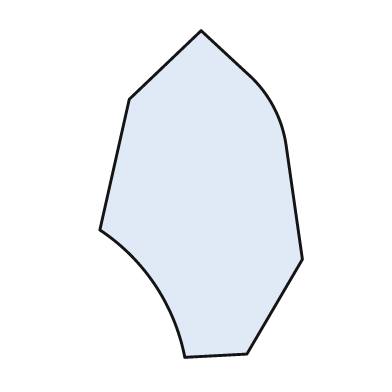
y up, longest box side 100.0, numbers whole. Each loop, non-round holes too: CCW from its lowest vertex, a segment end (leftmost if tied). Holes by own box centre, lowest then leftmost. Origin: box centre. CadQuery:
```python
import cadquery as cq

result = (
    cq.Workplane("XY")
    .moveTo(-5.0, -50.0)
    .lineTo(14.0, -49.0)
    .lineTo(31.0, -20.0)
    .lineTo(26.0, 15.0)
    .threePointArc((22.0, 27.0), (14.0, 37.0))
    .lineTo(0.0, 50.0)
    .lineTo(-22.0, 29.0)
    .lineTo(-31.0, -11.0)
    .threePointArc((-14.0, -28.0), (-5.0, -50.0))
    .close()
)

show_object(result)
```